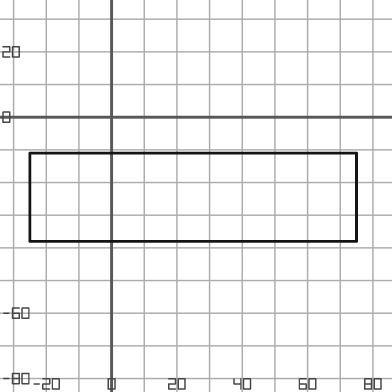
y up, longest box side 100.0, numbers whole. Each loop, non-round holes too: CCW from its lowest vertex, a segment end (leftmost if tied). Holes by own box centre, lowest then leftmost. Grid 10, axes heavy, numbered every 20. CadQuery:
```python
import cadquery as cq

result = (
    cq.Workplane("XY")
    .moveTo(-25.0, -38.0)
    .lineTo(75.0, -38.0)
    .lineTo(75.0, -11.0)
    .lineTo(-25.0, -11.0)
    .close()
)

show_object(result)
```